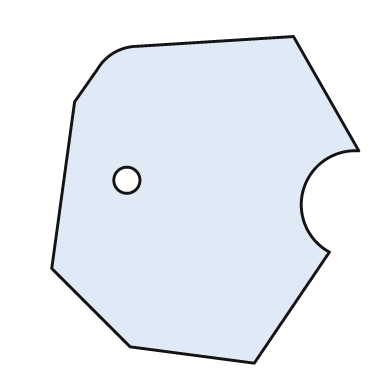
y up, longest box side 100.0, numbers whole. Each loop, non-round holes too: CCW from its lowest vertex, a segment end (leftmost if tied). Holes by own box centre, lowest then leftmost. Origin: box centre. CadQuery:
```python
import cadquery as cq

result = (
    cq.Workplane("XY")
    .moveTo(15.0, -50.0)
    .lineTo(38.0, -16.0)
    .threePointArc((30.0, 3.0), (47.0, 15.0))
    .lineTo(27.0, 50.0)
    .lineTo(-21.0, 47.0)
    .threePointArc((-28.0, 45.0), (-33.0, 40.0))
    .lineTo(-40.0, 30.0)
    .lineTo(-47.0, -21.0)
    .lineTo(-23.0, -45.0)
    .close()
    .moveTo(-24.0, 6.0)
    .circle(4.0)
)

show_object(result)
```